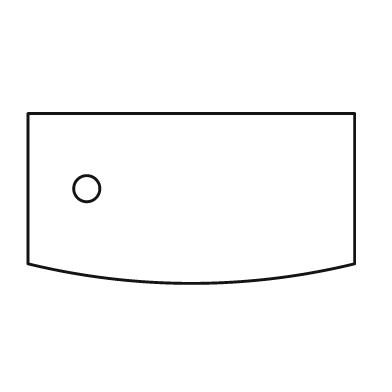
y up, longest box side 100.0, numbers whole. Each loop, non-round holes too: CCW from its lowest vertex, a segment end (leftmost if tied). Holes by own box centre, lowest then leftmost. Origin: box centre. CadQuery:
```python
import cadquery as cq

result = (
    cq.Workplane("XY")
    .moveTo(-50.0, -20.0)
    .threePointArc((0.0, -26.0), (50.0, -20.0))
    .lineTo(50.0, 26.0)
    .lineTo(-50.0, 26.0)
    .close()
    .moveTo(-32.0, 3.0)
    .circle(4.0)
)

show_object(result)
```